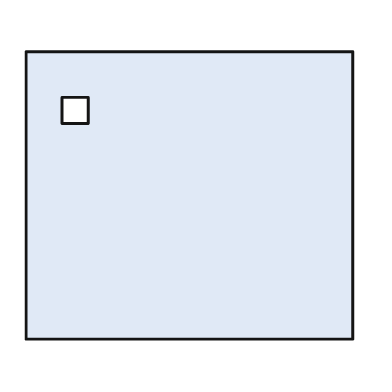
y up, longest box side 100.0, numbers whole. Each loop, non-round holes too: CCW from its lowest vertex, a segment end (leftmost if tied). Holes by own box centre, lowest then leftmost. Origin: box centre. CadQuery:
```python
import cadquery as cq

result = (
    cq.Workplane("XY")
    .moveTo(-50.0, -44.0)
    .lineTo(50.0, -44.0)
    .lineTo(50.0, 44.0)
    .lineTo(-50.0, 44.0)
    .close()
    .moveTo(-39.0, 22.0)
    .lineTo(-31.0, 22.0)
    .lineTo(-31.0, 30.0)
    .lineTo(-39.0, 30.0)
    .close()
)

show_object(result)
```